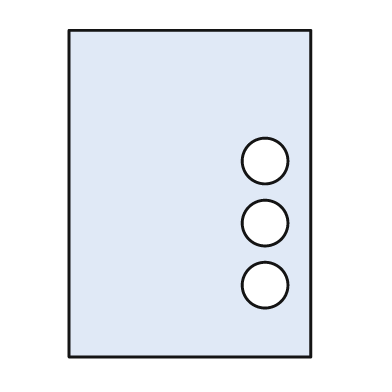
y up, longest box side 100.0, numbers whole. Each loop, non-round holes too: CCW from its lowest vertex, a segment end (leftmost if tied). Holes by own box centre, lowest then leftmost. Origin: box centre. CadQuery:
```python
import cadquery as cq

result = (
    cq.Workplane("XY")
    .moveTo(-37.0, -50.0)
    .lineTo(37.0, -50.0)
    .lineTo(37.0, 50.0)
    .lineTo(-37.0, 50.0)
    .close()
    .moveTo(23.0, -28.0)
    .circle(7.0)
    .moveTo(23.0, -9.0)
    .circle(7.0)
    .moveTo(23.0, 10.0)
    .circle(7.0)
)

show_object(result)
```